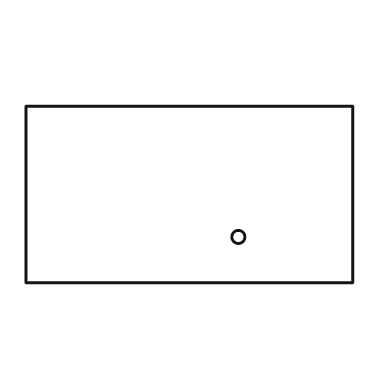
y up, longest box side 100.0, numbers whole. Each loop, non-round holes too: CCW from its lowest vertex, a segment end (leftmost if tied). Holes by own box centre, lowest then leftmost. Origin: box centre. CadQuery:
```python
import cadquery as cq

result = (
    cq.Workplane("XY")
    .moveTo(-50.0, -27.0)
    .lineTo(50.0, -27.0)
    .lineTo(50.0, 27.0)
    .lineTo(-50.0, 27.0)
    .close()
    .moveTo(15.0, -13.0)
    .circle(2.0)
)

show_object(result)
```